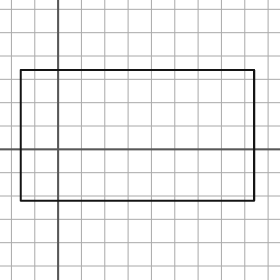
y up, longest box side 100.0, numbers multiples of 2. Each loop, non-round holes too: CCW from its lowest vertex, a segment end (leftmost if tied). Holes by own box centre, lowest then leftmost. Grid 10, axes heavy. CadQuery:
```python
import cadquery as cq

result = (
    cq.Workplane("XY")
    .moveTo(-16.0, -22.0)
    .lineTo(84.0, -22.0)
    .lineTo(84.0, 34.0)
    .lineTo(-16.0, 34.0)
    .close()
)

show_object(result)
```